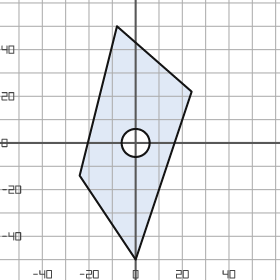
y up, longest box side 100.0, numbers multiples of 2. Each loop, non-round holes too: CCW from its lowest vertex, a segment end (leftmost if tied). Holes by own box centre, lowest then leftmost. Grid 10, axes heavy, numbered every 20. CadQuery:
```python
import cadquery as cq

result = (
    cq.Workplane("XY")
    .moveTo(0.0, -50.0)
    .lineTo(24.0, 22.0)
    .lineTo(-8.0, 50.0)
    .lineTo(-24.0, -14.0)
    .close()
    .moveTo(0.0, 0.0)
    .circle(6.0)
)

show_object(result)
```